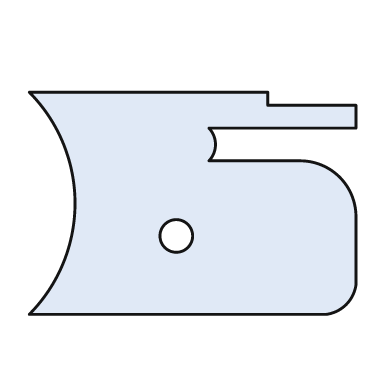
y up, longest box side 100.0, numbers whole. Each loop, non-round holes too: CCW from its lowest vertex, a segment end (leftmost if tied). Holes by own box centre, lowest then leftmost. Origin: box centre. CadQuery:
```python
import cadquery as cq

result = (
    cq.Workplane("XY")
    .moveTo(-50.0, -34.0)
    .lineTo(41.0, -34.0)
    .threePointArc((47.0, -31.0), (50.0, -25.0))
    .lineTo(50.0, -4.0)
    .threePointArc((45.0, 8.0), (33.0, 13.0))
    .lineTo(5.0, 13.0)
    .threePointArc((7.0, 18.0), (5.0, 23.0))
    .lineTo(50.0, 23.0)
    .lineTo(50.0, 30.0)
    .lineTo(23.0, 30.0)
    .lineTo(23.0, 34.0)
    .lineTo(-50.0, 34.0)
    .threePointArc((-36.0, 0.0), (-50.0, -34.0))
    .close()
    .moveTo(-5.0, -10.0)
    .circle(5.0)
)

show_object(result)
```